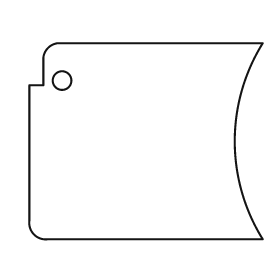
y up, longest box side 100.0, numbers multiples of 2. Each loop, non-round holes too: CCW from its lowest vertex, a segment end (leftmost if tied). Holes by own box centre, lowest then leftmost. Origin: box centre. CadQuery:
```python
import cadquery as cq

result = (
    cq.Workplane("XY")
    .moveTo(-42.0, -42.0)
    .lineTo(50.0, -42.0)
    .threePointArc((38.0, 0.0), (50.0, 42.0))
    .lineTo(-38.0, 42.0)
    .threePointArc((-42.0, 40.0), (-44.0, 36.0))
    .lineTo(-44.0, 24.0)
    .lineTo(-50.0, 24.0)
    .lineTo(-50.0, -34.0)
    .threePointArc((-48.0, -40.0), (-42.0, -42.0))
    .close()
    .moveTo(-36.0, 26.0)
    .circle(4.0)
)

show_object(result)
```